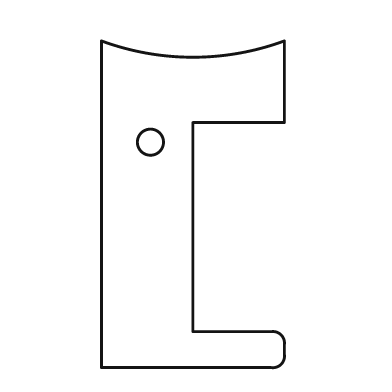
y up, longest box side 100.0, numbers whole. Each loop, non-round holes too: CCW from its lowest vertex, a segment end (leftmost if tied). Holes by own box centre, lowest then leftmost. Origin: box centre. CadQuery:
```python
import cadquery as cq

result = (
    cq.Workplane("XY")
    .moveTo(-28.0, -50.0)
    .lineTo(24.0, -50.0)
    .threePointArc((27.0, -49.0), (28.0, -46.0))
    .lineTo(28.0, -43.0)
    .threePointArc((27.0, -40.0), (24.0, -39.0))
    .lineTo(0.0, -39.0)
    .lineTo(0.0, 25.0)
    .lineTo(28.0, 25.0)
    .lineTo(28.0, 50.0)
    .threePointArc((0.0, 45.0), (-28.0, 50.0))
    .close()
    .moveTo(-13.0, 19.0)
    .circle(4.0)
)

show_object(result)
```